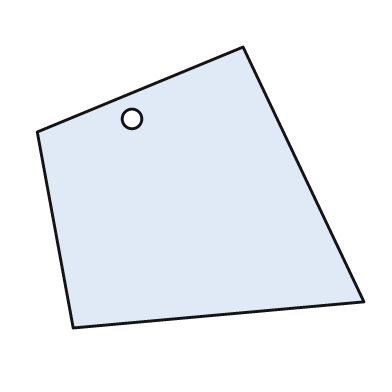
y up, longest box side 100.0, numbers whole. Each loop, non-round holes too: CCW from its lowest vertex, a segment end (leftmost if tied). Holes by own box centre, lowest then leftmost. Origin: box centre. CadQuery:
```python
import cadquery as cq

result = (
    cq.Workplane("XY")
    .moveTo(-39.0, -43.0)
    .lineTo(50.0, -35.0)
    .lineTo(13.0, 43.0)
    .lineTo(-50.0, 17.0)
    .close()
    .moveTo(-21.0, 21.0)
    .circle(3.0)
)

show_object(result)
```